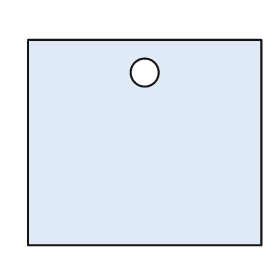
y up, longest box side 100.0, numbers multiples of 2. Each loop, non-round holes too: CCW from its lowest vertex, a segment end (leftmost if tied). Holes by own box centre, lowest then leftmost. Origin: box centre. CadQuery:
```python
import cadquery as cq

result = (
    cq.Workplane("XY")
    .moveTo(-50.0, -44.0)
    .lineTo(50.0, -44.0)
    .lineTo(50.0, 44.0)
    .lineTo(-50.0, 44.0)
    .close()
    .moveTo(0.0, 30.0)
    .circle(6.0)
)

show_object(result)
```